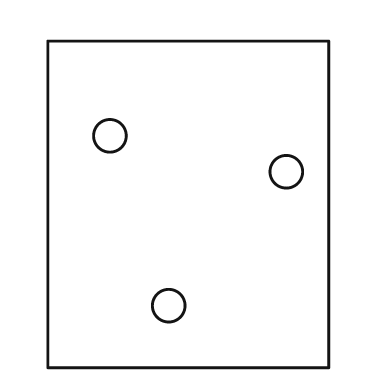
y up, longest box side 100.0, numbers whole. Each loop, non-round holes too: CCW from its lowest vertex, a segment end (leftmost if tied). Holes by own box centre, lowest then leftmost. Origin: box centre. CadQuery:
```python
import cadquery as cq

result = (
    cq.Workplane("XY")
    .moveTo(-43.0, -50.0)
    .lineTo(43.0, -50.0)
    .lineTo(43.0, 50.0)
    .lineTo(-43.0, 50.0)
    .close()
    .moveTo(-6.0, -31.0)
    .circle(5.0)
    .moveTo(30.0, 10.0)
    .circle(5.0)
    .moveTo(-24.0, 21.0)
    .circle(5.0)
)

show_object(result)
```